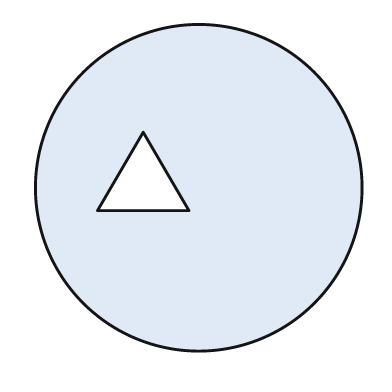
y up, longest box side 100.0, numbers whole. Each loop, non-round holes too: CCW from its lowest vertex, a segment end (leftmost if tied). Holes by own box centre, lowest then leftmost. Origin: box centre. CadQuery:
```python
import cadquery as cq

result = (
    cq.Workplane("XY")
    .moveTo(0.0, 0.0)
    .circle(50.0)
    .moveTo(-31.0, -7.0)
    .lineTo(-3.0, -7.0)
    .lineTo(-17.0, 17.0)
    .close()
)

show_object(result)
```